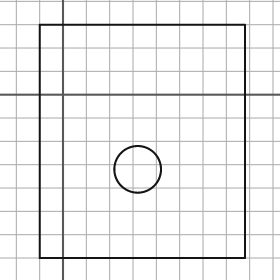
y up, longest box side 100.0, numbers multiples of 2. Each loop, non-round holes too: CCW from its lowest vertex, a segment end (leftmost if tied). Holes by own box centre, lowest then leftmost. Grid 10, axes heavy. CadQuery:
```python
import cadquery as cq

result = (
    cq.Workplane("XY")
    .moveTo(-10.0, -70.0)
    .lineTo(78.0, -70.0)
    .lineTo(78.0, 30.0)
    .lineTo(-10.0, 30.0)
    .close()
    .moveTo(32.0, -32.0)
    .circle(10.0)
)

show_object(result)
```